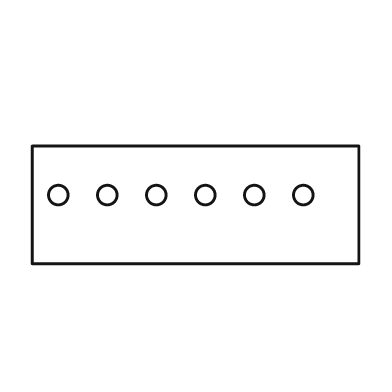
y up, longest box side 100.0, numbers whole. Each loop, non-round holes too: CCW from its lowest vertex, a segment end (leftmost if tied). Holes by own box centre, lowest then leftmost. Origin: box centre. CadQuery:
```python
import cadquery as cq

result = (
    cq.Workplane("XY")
    .moveTo(-50.0, -18.0)
    .lineTo(50.0, -18.0)
    .lineTo(50.0, 18.0)
    .lineTo(-50.0, 18.0)
    .close()
    .moveTo(-42.0, 3.0)
    .circle(3.0)
    .moveTo(-27.0, 3.0)
    .circle(3.0)
    .moveTo(-12.0, 3.0)
    .circle(3.0)
    .moveTo(3.0, 3.0)
    .circle(3.0)
    .moveTo(18.0, 3.0)
    .circle(3.0)
    .moveTo(33.0, 3.0)
    .circle(3.0)
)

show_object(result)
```